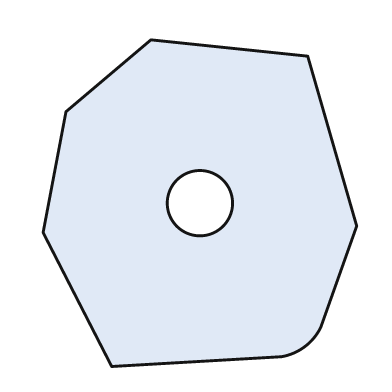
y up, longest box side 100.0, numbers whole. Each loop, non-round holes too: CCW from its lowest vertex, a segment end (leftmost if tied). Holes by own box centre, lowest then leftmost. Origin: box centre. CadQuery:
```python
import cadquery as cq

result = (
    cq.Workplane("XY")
    .moveTo(-27.0, -50.0)
    .lineTo(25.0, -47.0)
    .threePointArc((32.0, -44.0), (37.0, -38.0))
    .lineTo(48.0, -7.0)
    .lineTo(33.0, 45.0)
    .lineTo(-15.0, 50.0)
    .lineTo(-41.0, 28.0)
    .lineTo(-48.0, -9.0)
    .close()
    .moveTo(0.0, 0.0)
    .circle(10.0)
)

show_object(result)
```